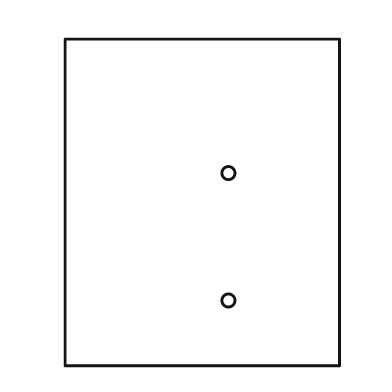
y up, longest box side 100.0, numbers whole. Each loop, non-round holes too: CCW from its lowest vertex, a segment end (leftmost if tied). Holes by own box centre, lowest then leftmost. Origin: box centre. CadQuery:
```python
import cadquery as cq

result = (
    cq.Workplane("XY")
    .moveTo(-42.0, -50.0)
    .lineTo(42.0, -50.0)
    .lineTo(42.0, 50.0)
    .lineTo(-42.0, 50.0)
    .close()
    .moveTo(8.0, -30.0)
    .circle(2.0)
    .moveTo(8.0, 9.0)
    .circle(2.0)
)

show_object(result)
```